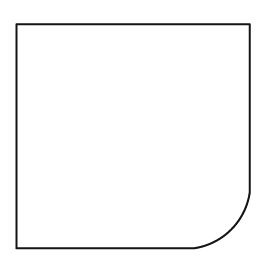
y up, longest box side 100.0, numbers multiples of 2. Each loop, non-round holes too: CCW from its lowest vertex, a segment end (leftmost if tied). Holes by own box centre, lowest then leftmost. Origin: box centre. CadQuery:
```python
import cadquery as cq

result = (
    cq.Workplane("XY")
    .moveTo(-50.0, -48.0)
    .lineTo(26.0, -48.0)
    .threePointArc((42.0, -40.0), (50.0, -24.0))
    .lineTo(50.0, 48.0)
    .lineTo(-50.0, 48.0)
    .close()
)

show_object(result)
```